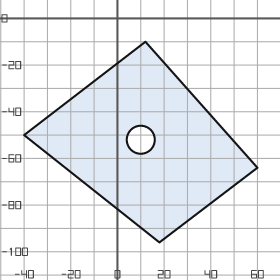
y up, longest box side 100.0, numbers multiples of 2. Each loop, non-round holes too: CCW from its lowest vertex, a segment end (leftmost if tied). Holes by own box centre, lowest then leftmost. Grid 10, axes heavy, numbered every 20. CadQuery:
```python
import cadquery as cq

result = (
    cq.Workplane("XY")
    .moveTo(18.0, -96.0)
    .lineTo(60.0, -64.0)
    .lineTo(12.0, -10.0)
    .lineTo(-40.0, -50.0)
    .close()
    .moveTo(10.0, -52.0)
    .circle(6.0)
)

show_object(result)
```